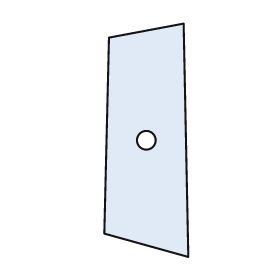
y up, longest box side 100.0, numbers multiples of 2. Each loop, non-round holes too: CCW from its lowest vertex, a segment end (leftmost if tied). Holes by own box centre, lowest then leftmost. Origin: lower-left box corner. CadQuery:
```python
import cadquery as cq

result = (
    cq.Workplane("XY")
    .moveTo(36.0, 0.0)
    .lineTo(34.0, 100.0)
    .lineTo(2.0, 94.0)
    .lineTo(0.0, 10.0)
    .close()
    .moveTo(18.0, 50.0)
    .circle(4.0)
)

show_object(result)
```